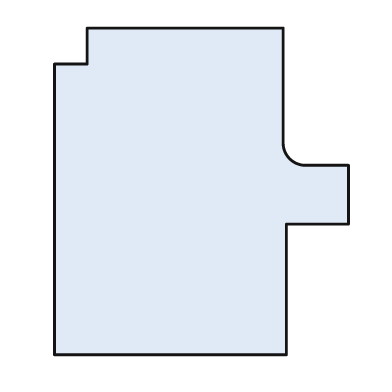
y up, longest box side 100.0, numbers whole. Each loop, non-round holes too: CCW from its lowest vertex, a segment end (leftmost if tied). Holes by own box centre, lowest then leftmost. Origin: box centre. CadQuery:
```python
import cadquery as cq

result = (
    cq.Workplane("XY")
    .moveTo(-45.0, -50.0)
    .lineTo(26.0, -50.0)
    .lineTo(26.0, -10.0)
    .lineTo(45.0, -10.0)
    .lineTo(45.0, 8.0)
    .lineTo(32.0, 8.0)
    .threePointArc((27.0, 10.0), (25.0, 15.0))
    .lineTo(25.0, 50.0)
    .lineTo(-35.0, 50.0)
    .lineTo(-35.0, 39.0)
    .lineTo(-45.0, 39.0)
    .close()
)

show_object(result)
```